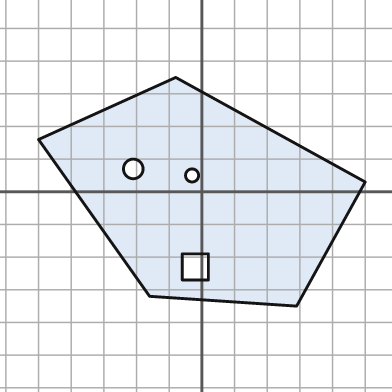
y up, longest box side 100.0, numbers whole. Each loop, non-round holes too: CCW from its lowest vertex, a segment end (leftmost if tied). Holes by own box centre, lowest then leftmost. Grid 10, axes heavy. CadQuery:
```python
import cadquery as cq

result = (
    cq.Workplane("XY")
    .moveTo(29.0, -35.0)
    .lineTo(50.0, 3.0)
    .lineTo(-8.0, 35.0)
    .lineTo(-50.0, 16.0)
    .lineTo(-16.0, -32.0)
    .close()
    .moveTo(-6.0, -27.0)
    .lineTo(2.0, -27.0)
    .lineTo(2.0, -19.0)
    .lineTo(-6.0, -19.0)
    .close()
    .moveTo(-3.0, 5.0)
    .circle(2.0)
    .moveTo(-21.0, 7.0)
    .circle(3.0)
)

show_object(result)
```